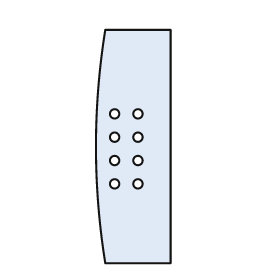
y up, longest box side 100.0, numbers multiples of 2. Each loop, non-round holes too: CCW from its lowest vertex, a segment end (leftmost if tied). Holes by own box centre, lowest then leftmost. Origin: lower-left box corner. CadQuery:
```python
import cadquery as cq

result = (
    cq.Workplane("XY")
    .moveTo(4.0, 0.0)
    .lineTo(32.0, 0.0)
    .lineTo(32.0, 100.0)
    .lineTo(4.0, 100.0)
    .threePointArc((0.0, 50.0), (4.0, 0.0))
    .close()
    .moveTo(8.0, 34.0)
    .circle(2.0)
    .moveTo(18.0, 34.0)
    .circle(2.0)
    .moveTo(8.0, 44.0)
    .circle(2.0)
    .moveTo(18.0, 44.0)
    .circle(2.0)
    .moveTo(8.0, 54.0)
    .circle(2.0)
    .moveTo(18.0, 54.0)
    .circle(2.0)
    .moveTo(8.0, 64.0)
    .circle(2.0)
    .moveTo(18.0, 64.0)
    .circle(2.0)
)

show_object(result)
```